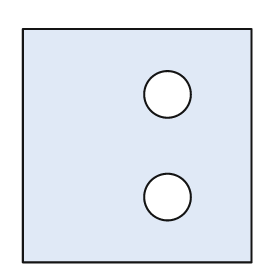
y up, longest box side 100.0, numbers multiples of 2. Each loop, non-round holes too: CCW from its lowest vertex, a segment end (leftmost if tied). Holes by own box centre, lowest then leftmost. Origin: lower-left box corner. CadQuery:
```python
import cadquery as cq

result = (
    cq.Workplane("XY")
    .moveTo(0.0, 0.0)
    .lineTo(98.0, 0.0)
    .lineTo(98.0, 100.0)
    .lineTo(0.0, 100.0)
    .close()
    .moveTo(62.0, 28.0)
    .circle(10.0)
    .moveTo(62.0, 72.0)
    .circle(10.0)
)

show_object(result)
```